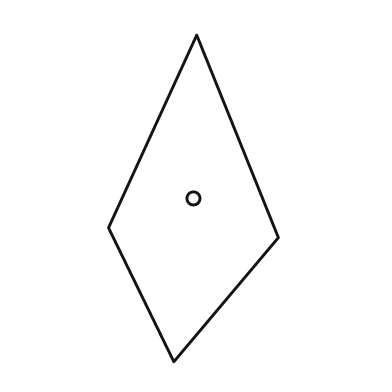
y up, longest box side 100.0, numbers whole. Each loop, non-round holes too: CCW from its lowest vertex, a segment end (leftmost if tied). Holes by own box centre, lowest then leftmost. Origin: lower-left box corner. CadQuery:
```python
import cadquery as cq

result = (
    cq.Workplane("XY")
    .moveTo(20.0, 0.0)
    .lineTo(52.0, 38.0)
    .lineTo(27.0, 100.0)
    .lineTo(0.0, 41.0)
    .close()
    .moveTo(26.0, 50.0)
    .circle(2.0)
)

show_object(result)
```